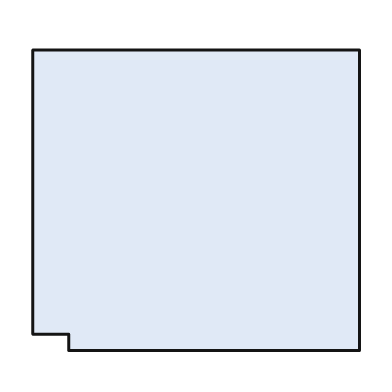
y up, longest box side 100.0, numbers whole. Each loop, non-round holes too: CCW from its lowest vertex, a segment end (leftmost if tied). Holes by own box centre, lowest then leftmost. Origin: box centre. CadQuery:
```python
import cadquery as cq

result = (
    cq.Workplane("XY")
    .moveTo(-39.0, -46.0)
    .lineTo(50.0, -46.0)
    .lineTo(50.0, 46.0)
    .lineTo(-50.0, 46.0)
    .lineTo(-50.0, -41.0)
    .lineTo(-39.0, -41.0)
    .close()
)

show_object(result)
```